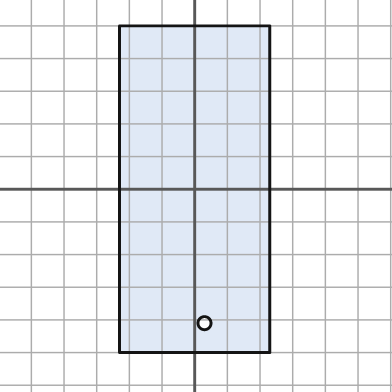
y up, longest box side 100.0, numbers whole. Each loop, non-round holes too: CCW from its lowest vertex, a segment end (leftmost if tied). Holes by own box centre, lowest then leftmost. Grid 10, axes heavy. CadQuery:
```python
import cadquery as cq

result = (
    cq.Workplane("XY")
    .moveTo(-23.0, -50.0)
    .lineTo(23.0, -50.0)
    .lineTo(23.0, 50.0)
    .lineTo(-23.0, 50.0)
    .close()
    .moveTo(3.0, -41.0)
    .circle(2.0)
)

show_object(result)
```